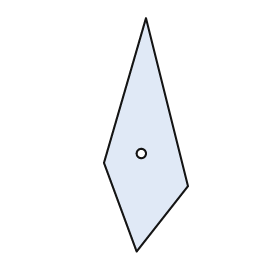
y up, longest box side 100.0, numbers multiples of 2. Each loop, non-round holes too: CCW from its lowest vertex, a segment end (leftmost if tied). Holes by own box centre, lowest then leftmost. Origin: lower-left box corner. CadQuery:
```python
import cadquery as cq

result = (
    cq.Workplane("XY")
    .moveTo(14.0, 0.0)
    .lineTo(36.0, 28.0)
    .lineTo(18.0, 100.0)
    .lineTo(0.0, 38.0)
    .close()
    .moveTo(16.0, 42.0)
    .circle(2.0)
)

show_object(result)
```